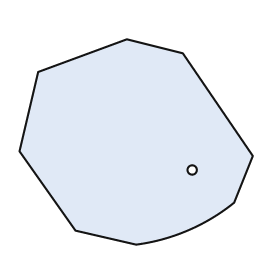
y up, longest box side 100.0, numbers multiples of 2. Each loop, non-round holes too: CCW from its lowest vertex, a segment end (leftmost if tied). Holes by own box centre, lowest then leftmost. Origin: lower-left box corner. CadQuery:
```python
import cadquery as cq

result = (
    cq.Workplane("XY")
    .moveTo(50.0, 0.0)
    .threePointArc((72.0, 6.0), (92.0, 18.0))
    .lineTo(100.0, 38.0)
    .lineTo(70.0, 82.0)
    .lineTo(46.0, 88.0)
    .lineTo(8.0, 74.0)
    .lineTo(0.0, 40.0)
    .lineTo(24.0, 6.0)
    .close()
    .moveTo(74.0, 32.0)
    .circle(2.0)
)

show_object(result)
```